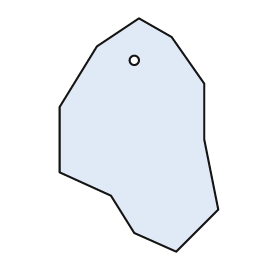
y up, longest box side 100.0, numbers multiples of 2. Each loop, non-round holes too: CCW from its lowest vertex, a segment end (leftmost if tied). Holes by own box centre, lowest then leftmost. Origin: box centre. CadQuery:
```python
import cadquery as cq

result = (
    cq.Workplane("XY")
    .moveTo(16.0, -50.0)
    .lineTo(34.0, -32.0)
    .lineTo(28.0, -2.0)
    .lineTo(28.0, 22.0)
    .lineTo(14.0, 42.0)
    .lineTo(0.0, 50.0)
    .lineTo(-18.0, 38.0)
    .lineTo(-34.0, 12.0)
    .lineTo(-34.0, -16.0)
    .lineTo(-12.0, -26.0)
    .lineTo(-2.0, -42.0)
    .close()
    .moveTo(-2.0, 32.0)
    .circle(2.0)
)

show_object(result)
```